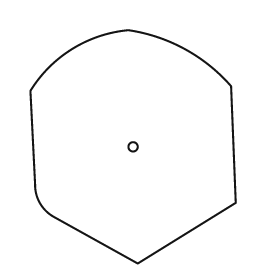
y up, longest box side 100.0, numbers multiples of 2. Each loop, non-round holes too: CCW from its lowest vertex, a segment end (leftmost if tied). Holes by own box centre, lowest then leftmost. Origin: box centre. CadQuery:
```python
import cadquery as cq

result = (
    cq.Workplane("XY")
    .moveTo(2.0, -50.0)
    .lineTo(44.0, -24.0)
    .lineTo(42.0, 26.0)
    .threePointArc((22.0, 42.0), (-2.0, 50.0))
    .threePointArc((-26.0, 42.0), (-44.0, 24.0))
    .lineTo(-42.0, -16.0)
    .threePointArc((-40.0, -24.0), (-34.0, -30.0))
    .close()
    .moveTo(0.0, 0.0)
    .circle(2.0)
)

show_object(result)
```